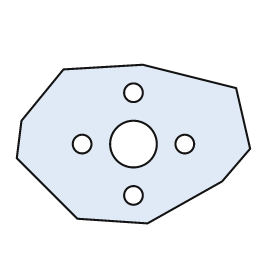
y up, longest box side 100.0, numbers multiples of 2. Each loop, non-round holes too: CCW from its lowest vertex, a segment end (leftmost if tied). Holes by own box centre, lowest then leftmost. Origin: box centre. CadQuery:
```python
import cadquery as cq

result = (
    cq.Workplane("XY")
    .moveTo(6.0, -34.0)
    .lineTo(38.0, -16.0)
    .lineTo(50.0, -2.0)
    .lineTo(44.0, 24.0)
    .lineTo(4.0, 34.0)
    .lineTo(-30.0, 32.0)
    .lineTo(-48.0, 10.0)
    .lineTo(-50.0, -6.0)
    .lineTo(-24.0, -32.0)
    .close()
    .moveTo(0.0, -22.0)
    .circle(4.0)
    .moveTo(-22.0, 0.0)
    .circle(4.0)
    .moveTo(0.0, 0.0)
    .circle(10.0)
    .moveTo(22.0, 0.0)
    .circle(4.0)
    .moveTo(0.0, 22.0)
    .circle(4.0)
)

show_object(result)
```